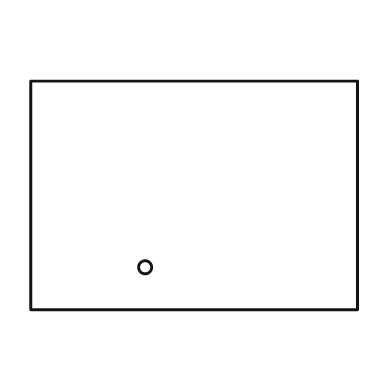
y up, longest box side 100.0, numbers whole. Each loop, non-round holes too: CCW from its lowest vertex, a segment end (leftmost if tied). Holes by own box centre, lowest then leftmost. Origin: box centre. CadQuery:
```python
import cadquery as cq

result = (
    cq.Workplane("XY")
    .moveTo(-50.0, -35.0)
    .lineTo(50.0, -35.0)
    .lineTo(50.0, 35.0)
    .lineTo(-50.0, 35.0)
    .close()
    .moveTo(-15.0, -22.0)
    .circle(2.0)
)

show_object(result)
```